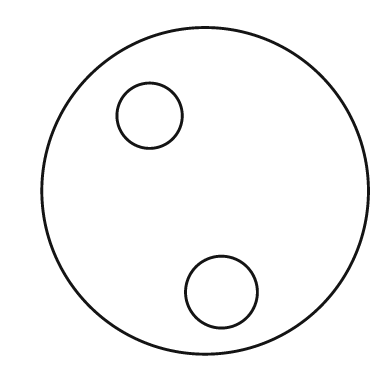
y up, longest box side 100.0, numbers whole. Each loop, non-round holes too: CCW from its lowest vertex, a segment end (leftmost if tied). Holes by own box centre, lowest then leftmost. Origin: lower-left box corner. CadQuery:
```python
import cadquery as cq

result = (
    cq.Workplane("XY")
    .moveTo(50.0, 50.0)
    .circle(50.0)
    .moveTo(55.0, 19.0)
    .circle(11.0)
    .moveTo(33.0, 73.0)
    .circle(10.0)
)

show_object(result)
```